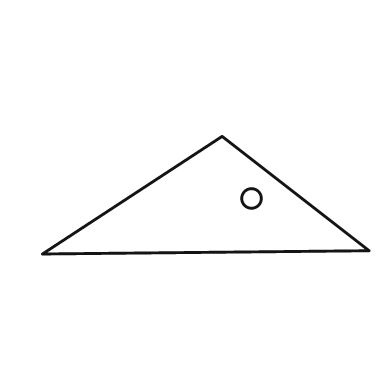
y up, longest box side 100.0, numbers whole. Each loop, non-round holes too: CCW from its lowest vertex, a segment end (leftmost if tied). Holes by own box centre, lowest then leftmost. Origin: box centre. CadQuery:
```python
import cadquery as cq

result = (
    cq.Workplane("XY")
    .moveTo(-50.0, -18.0)
    .lineTo(50.0, -17.0)
    .lineTo(5.0, 18.0)
    .close()
    .moveTo(14.0, -1.0)
    .circle(3.0)
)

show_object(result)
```